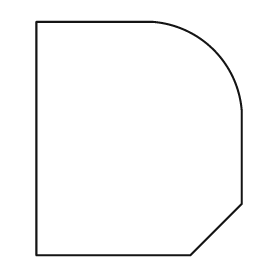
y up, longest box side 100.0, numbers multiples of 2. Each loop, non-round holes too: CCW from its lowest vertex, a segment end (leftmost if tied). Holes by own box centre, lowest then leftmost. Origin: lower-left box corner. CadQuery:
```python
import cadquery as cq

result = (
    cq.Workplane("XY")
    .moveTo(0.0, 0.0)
    .lineTo(66.0, 0.0)
    .lineTo(88.0, 22.0)
    .lineTo(88.0, 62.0)
    .threePointArc((76.0, 88.0), (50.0, 100.0))
    .lineTo(0.0, 100.0)
    .close()
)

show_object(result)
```